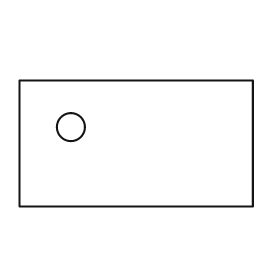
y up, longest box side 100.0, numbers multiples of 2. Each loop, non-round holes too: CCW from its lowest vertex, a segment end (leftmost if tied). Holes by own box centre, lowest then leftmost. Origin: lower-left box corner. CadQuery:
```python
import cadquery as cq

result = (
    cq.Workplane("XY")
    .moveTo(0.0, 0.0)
    .lineTo(100.0, 0.0)
    .lineTo(100.0, 54.0)
    .lineTo(0.0, 54.0)
    .close()
    .moveTo(22.0, 34.0)
    .circle(6.0)
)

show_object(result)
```